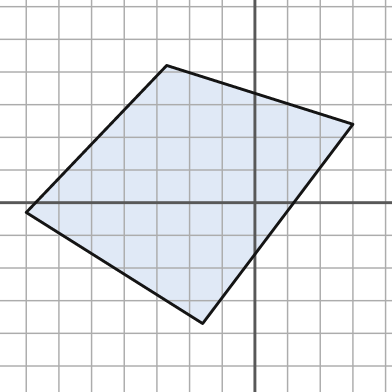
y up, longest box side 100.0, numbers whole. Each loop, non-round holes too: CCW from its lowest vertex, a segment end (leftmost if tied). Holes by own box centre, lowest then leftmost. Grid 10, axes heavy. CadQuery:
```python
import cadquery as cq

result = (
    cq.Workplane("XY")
    .moveTo(-16.0, -37.0)
    .lineTo(30.0, 24.0)
    .lineTo(-27.0, 42.0)
    .lineTo(-70.0, -3.0)
    .close()
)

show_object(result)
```